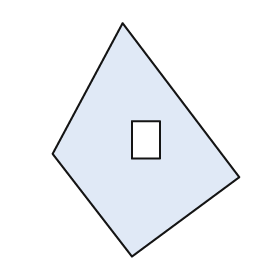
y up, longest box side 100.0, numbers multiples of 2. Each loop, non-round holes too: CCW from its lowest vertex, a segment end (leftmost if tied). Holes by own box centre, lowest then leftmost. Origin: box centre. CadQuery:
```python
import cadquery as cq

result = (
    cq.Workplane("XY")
    .moveTo(-6.0, -50.0)
    .lineTo(40.0, -16.0)
    .lineTo(-10.0, 50.0)
    .lineTo(-40.0, -6.0)
    .close()
    .moveTo(-6.0, -8.0)
    .lineTo(6.0, -8.0)
    .lineTo(6.0, 8.0)
    .lineTo(-6.0, 8.0)
    .close()
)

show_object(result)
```